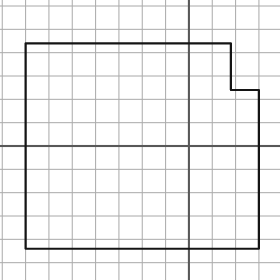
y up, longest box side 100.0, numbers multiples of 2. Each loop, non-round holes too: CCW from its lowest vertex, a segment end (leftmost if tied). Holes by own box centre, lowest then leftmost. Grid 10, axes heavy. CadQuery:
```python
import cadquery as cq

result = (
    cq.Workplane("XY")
    .moveTo(-70.0, -44.0)
    .lineTo(30.0, -44.0)
    .lineTo(30.0, 24.0)
    .lineTo(18.0, 24.0)
    .lineTo(18.0, 44.0)
    .lineTo(-70.0, 44.0)
    .close()
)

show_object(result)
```